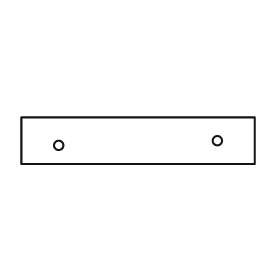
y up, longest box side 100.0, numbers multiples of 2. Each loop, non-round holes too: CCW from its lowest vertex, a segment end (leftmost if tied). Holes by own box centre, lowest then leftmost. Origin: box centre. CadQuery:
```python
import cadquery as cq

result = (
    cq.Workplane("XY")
    .moveTo(-50.0, -10.0)
    .lineTo(50.0, -10.0)
    .lineTo(50.0, 10.0)
    .lineTo(-50.0, 10.0)
    .close()
    .moveTo(-34.0, -2.0)
    .circle(2.0)
    .moveTo(34.0, 0.0)
    .circle(2.0)
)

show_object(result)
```